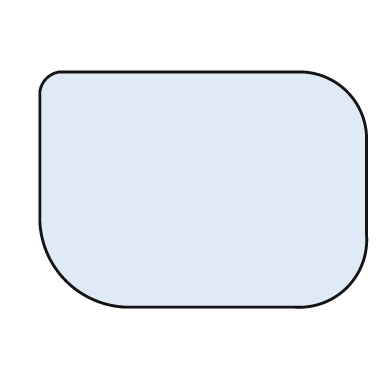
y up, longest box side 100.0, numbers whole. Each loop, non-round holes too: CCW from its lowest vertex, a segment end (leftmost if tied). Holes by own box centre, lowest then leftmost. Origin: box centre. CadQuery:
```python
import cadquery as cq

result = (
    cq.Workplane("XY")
    .moveTo(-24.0, -36.0)
    .lineTo(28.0, -36.0)
    .threePointArc((44.0, -30.0), (50.0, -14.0))
    .lineTo(50.0, 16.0)
    .threePointArc((44.0, 30.0), (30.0, 36.0))
    .lineTo(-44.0, 36.0)
    .threePointArc((-48.0, 34.0), (-50.0, 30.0))
    .lineTo(-50.0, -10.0)
    .threePointArc((-42.0, -28.0), (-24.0, -36.0))
    .close()
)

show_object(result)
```